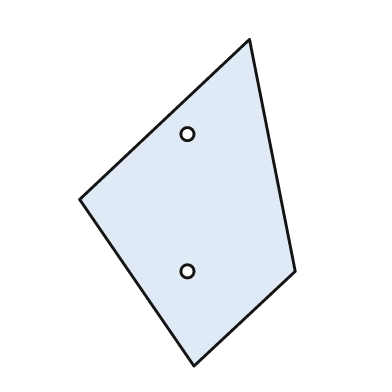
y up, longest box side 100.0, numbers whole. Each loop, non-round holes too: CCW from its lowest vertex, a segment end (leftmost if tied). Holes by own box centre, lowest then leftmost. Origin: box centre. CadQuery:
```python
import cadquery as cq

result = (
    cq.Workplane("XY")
    .moveTo(2.0, -50.0)
    .lineTo(33.0, -21.0)
    .lineTo(19.0, 50.0)
    .lineTo(-33.0, 1.0)
    .close()
    .moveTo(0.0, -21.0)
    .circle(2.0)
    .moveTo(0.0, 21.0)
    .circle(2.0)
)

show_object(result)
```